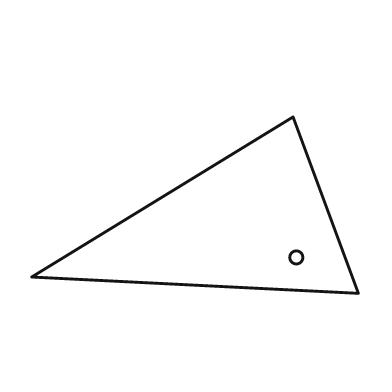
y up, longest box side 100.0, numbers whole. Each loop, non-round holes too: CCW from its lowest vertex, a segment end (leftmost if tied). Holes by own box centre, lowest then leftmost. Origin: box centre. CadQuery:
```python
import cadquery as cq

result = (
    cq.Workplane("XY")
    .moveTo(50.0, -27.0)
    .lineTo(30.0, 27.0)
    .lineTo(-50.0, -22.0)
    .close()
    .moveTo(31.0, -16.0)
    .circle(2.0)
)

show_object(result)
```